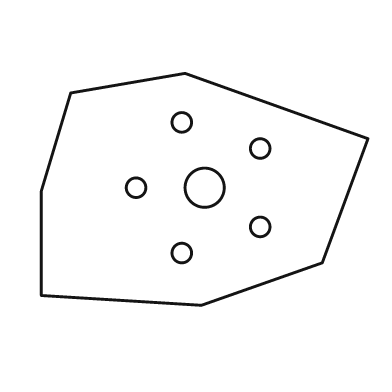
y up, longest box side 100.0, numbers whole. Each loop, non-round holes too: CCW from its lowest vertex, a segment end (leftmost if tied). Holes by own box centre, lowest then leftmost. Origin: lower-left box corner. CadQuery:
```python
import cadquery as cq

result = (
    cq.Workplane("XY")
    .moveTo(49.0, 0.0)
    .lineTo(86.0, 13.0)
    .lineTo(100.0, 51.0)
    .lineTo(44.0, 71.0)
    .lineTo(9.0, 65.0)
    .lineTo(0.0, 35.0)
    .lineTo(0.0, 3.0)
    .close()
    .moveTo(43.0, 16.0)
    .circle(3.0)
    .moveTo(67.0, 24.0)
    .circle(3.0)
    .moveTo(29.0, 36.0)
    .circle(3.0)
    .moveTo(50.0, 36.0)
    .circle(6.0)
    .moveTo(67.0, 48.0)
    .circle(3.0)
    .moveTo(43.0, 56.0)
    .circle(3.0)
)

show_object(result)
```